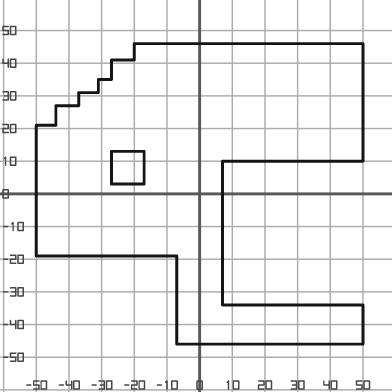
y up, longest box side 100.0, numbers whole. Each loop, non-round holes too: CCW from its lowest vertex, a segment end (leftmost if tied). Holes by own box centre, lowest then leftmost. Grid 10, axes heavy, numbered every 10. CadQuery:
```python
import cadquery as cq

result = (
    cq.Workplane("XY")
    .moveTo(-7.0, -46.0)
    .lineTo(50.0, -46.0)
    .lineTo(50.0, -34.0)
    .lineTo(7.0, -34.0)
    .lineTo(7.0, 10.0)
    .lineTo(50.0, 10.0)
    .lineTo(50.0, 46.0)
    .lineTo(-20.0, 46.0)
    .lineTo(-20.0, 41.0)
    .lineTo(-27.0, 41.0)
    .lineTo(-27.0, 35.0)
    .lineTo(-31.0, 35.0)
    .lineTo(-31.0, 31.0)
    .lineTo(-37.0, 31.0)
    .lineTo(-37.0, 27.0)
    .lineTo(-44.0, 27.0)
    .lineTo(-44.0, 21.0)
    .lineTo(-50.0, 21.0)
    .lineTo(-50.0, -19.0)
    .lineTo(-7.0, -19.0)
    .close()
    .moveTo(-27.0, 3.0)
    .lineTo(-17.0, 3.0)
    .lineTo(-17.0, 13.0)
    .lineTo(-27.0, 13.0)
    .close()
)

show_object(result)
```